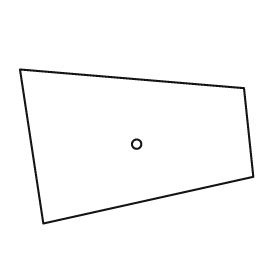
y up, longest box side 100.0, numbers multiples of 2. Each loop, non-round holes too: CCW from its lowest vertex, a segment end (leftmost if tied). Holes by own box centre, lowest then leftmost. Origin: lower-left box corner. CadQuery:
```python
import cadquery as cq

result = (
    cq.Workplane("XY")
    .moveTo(10.0, 0.0)
    .lineTo(100.0, 20.0)
    .lineTo(96.0, 58.0)
    .lineTo(0.0, 66.0)
    .close()
    .moveTo(50.0, 34.0)
    .circle(2.0)
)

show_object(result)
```